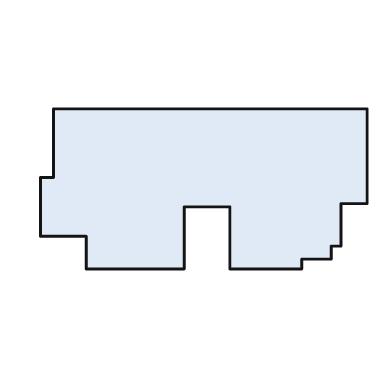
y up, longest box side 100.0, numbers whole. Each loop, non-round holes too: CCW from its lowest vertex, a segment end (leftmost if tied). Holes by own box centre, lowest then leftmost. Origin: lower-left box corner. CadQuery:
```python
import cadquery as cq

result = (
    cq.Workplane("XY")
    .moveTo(14.0, 0.0)
    .lineTo(44.0, 0.0)
    .lineTo(44.0, 19.0)
    .lineTo(58.0, 19.0)
    .lineTo(58.0, 0.0)
    .lineTo(80.0, 0.0)
    .lineTo(80.0, 3.0)
    .lineTo(89.0, 3.0)
    .lineTo(89.0, 7.0)
    .lineTo(92.0, 7.0)
    .lineTo(92.0, 20.0)
    .lineTo(100.0, 20.0)
    .lineTo(100.0, 49.0)
    .lineTo(4.0, 49.0)
    .lineTo(4.0, 28.0)
    .lineTo(0.0, 28.0)
    .lineTo(0.0, 10.0)
    .lineTo(14.0, 10.0)
    .close()
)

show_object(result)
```